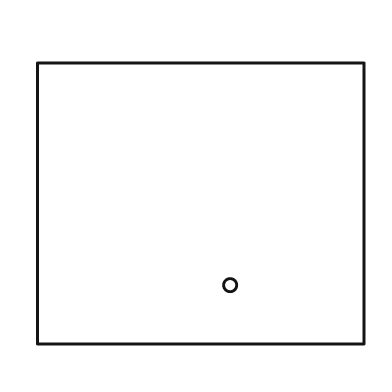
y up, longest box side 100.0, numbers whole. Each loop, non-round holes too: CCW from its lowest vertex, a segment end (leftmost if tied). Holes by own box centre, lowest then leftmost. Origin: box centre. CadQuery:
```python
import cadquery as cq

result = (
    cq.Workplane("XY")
    .moveTo(-50.0, -43.0)
    .lineTo(50.0, -43.0)
    .lineTo(50.0, 43.0)
    .lineTo(-50.0, 43.0)
    .close()
    .moveTo(9.0, -25.0)
    .circle(2.0)
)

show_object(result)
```